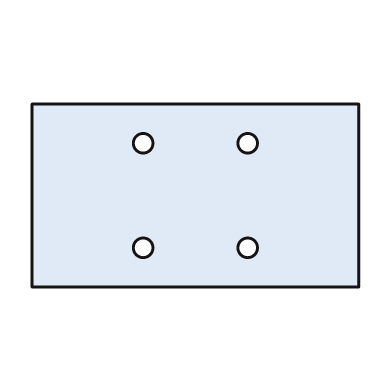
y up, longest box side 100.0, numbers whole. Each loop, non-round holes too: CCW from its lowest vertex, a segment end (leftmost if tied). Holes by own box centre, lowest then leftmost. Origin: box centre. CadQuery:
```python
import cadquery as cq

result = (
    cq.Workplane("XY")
    .moveTo(-50.0, -28.0)
    .lineTo(50.0, -28.0)
    .lineTo(50.0, 28.0)
    .lineTo(-50.0, 28.0)
    .close()
    .moveTo(-16.0, -16.0)
    .circle(3.0)
    .moveTo(16.0, -16.0)
    .circle(3.0)
    .moveTo(-16.0, 16.0)
    .circle(3.0)
    .moveTo(16.0, 16.0)
    .circle(3.0)
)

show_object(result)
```